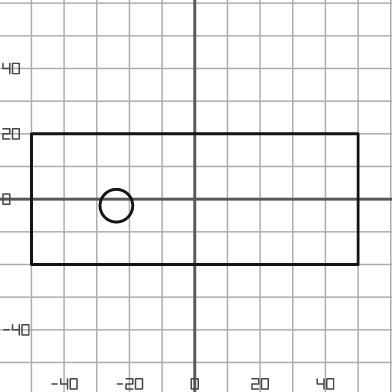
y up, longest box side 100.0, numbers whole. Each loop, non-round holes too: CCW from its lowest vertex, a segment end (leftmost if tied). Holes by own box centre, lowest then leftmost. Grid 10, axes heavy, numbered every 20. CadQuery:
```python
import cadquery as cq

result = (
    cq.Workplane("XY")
    .moveTo(-50.0, -20.0)
    .lineTo(50.0, -20.0)
    .lineTo(50.0, 20.0)
    .lineTo(-50.0, 20.0)
    .close()
    .moveTo(-24.0, -2.0)
    .circle(5.0)
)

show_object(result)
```